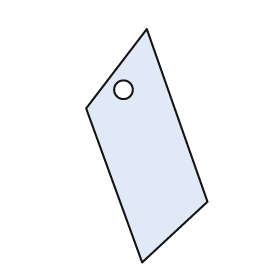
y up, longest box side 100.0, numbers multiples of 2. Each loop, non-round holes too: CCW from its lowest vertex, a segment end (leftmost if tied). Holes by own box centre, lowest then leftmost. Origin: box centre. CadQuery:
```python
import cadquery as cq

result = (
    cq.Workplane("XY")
    .moveTo(-2.0, -50.0)
    .lineTo(26.0, -24.0)
    .lineTo(0.0, 50.0)
    .lineTo(-26.0, 16.0)
    .close()
    .moveTo(-10.0, 24.0)
    .circle(4.0)
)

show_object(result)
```